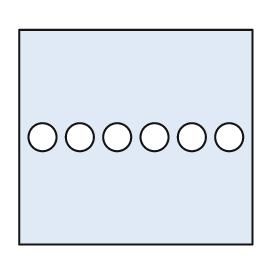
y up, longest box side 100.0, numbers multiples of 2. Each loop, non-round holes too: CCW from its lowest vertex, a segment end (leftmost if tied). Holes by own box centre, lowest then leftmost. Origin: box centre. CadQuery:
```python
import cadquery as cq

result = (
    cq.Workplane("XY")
    .moveTo(-50.0, -46.0)
    .lineTo(50.0, -46.0)
    .lineTo(50.0, 46.0)
    .lineTo(-50.0, 46.0)
    .close()
    .moveTo(-40.0, 0.0)
    .circle(6.0)
    .moveTo(-24.0, 0.0)
    .circle(6.0)
    .moveTo(-8.0, 0.0)
    .circle(6.0)
    .moveTo(8.0, 0.0)
    .circle(6.0)
    .moveTo(24.0, 0.0)
    .circle(6.0)
    .moveTo(40.0, 0.0)
    .circle(6.0)
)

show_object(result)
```